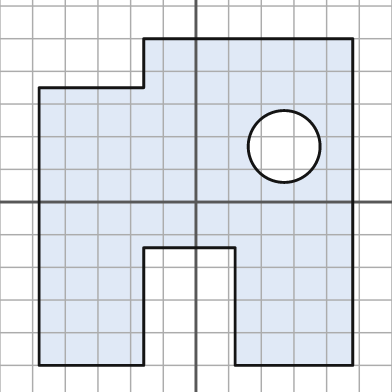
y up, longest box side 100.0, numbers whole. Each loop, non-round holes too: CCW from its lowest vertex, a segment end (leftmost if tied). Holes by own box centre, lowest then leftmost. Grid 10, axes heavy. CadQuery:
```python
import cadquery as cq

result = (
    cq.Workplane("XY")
    .moveTo(-48.0, -50.0)
    .lineTo(-16.0, -50.0)
    .lineTo(-16.0, -14.0)
    .lineTo(12.0, -14.0)
    .lineTo(12.0, -50.0)
    .lineTo(48.0, -50.0)
    .lineTo(48.0, 50.0)
    .lineTo(-16.0, 50.0)
    .lineTo(-16.0, 35.0)
    .lineTo(-48.0, 35.0)
    .close()
    .moveTo(27.0, 17.0)
    .circle(11.0)
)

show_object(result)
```